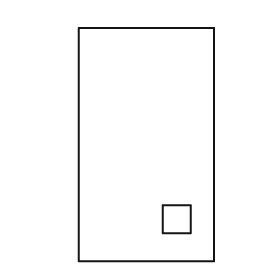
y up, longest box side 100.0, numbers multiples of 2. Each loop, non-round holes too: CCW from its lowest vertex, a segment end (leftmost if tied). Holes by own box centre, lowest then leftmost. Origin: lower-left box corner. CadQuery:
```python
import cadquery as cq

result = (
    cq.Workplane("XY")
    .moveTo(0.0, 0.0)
    .lineTo(58.0, 0.0)
    .lineTo(58.0, 100.0)
    .lineTo(0.0, 100.0)
    .close()
    .moveTo(36.0, 12.0)
    .lineTo(48.0, 12.0)
    .lineTo(48.0, 24.0)
    .lineTo(36.0, 24.0)
    .close()
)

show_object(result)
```